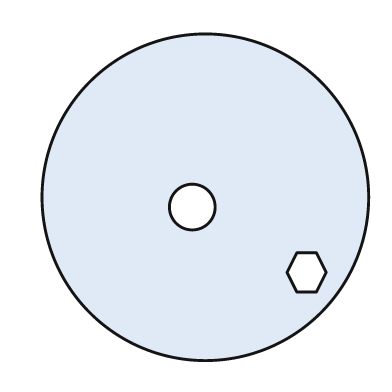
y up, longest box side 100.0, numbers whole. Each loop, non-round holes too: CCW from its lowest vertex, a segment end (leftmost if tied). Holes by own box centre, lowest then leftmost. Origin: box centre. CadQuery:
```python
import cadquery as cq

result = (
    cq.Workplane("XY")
    .moveTo(0.0, 0.0)
    .circle(50.0)
    .moveTo(28.0, -29.0)
    .lineTo(34.0, -29.0)
    .lineTo(37.0, -23.0)
    .lineTo(34.0, -17.0)
    .lineTo(28.0, -17.0)
    .lineTo(25.0, -23.0)
    .close()
    .moveTo(-4.0, -3.0)
    .circle(7.0)
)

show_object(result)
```